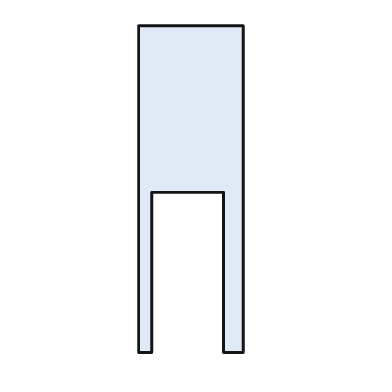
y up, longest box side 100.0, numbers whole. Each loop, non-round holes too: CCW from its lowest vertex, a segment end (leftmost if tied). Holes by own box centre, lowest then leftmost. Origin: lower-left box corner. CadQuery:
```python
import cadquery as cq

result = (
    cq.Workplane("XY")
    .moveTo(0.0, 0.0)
    .lineTo(4.0, 0.0)
    .lineTo(4.0, 49.0)
    .lineTo(26.0, 49.0)
    .lineTo(26.0, 0.0)
    .lineTo(32.0, 0.0)
    .lineTo(32.0, 100.0)
    .lineTo(0.0, 100.0)
    .close()
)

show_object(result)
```